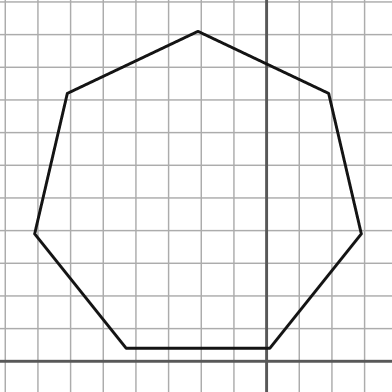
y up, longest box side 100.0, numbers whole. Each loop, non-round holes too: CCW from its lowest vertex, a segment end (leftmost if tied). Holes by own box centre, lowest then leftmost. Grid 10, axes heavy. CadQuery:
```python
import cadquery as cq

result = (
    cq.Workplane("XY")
    .moveTo(-43.0, 4.0)
    .lineTo(1.0, 4.0)
    .lineTo(29.0, 39.0)
    .lineTo(19.0, 82.0)
    .lineTo(-21.0, 101.0)
    .lineTo(-61.0, 82.0)
    .lineTo(-71.0, 39.0)
    .close()
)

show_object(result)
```